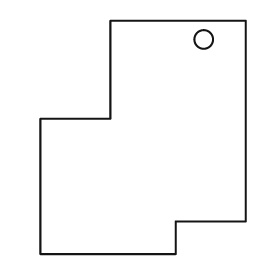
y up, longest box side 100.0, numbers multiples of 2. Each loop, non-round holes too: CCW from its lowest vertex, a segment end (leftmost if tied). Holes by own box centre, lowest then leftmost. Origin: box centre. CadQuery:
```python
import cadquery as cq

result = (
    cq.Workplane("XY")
    .moveTo(-44.0, -50.0)
    .lineTo(14.0, -50.0)
    .lineTo(14.0, -36.0)
    .lineTo(44.0, -36.0)
    .lineTo(44.0, 50.0)
    .lineTo(-14.0, 50.0)
    .lineTo(-14.0, 8.0)
    .lineTo(-44.0, 8.0)
    .close()
    .moveTo(26.0, 42.0)
    .circle(4.0)
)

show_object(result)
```